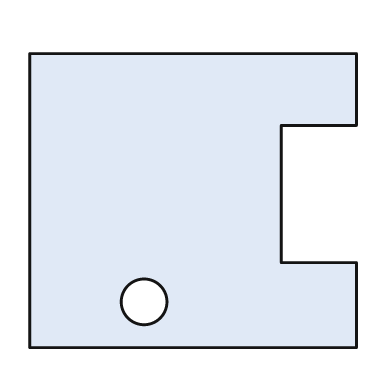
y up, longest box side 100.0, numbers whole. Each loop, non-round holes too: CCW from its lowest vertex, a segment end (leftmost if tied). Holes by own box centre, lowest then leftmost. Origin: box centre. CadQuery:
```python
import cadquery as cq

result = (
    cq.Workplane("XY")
    .moveTo(-50.0, -45.0)
    .lineTo(50.0, -45.0)
    .lineTo(50.0, -19.0)
    .lineTo(27.0, -19.0)
    .lineTo(27.0, 23.0)
    .lineTo(50.0, 23.0)
    .lineTo(50.0, 45.0)
    .lineTo(-50.0, 45.0)
    .close()
    .moveTo(-15.0, -31.0)
    .circle(7.0)
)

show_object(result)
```